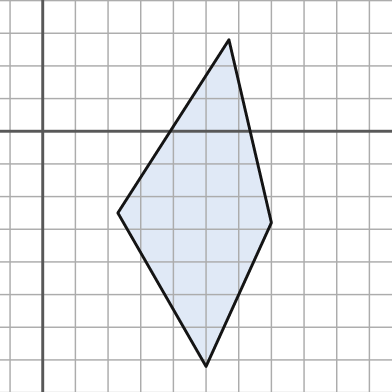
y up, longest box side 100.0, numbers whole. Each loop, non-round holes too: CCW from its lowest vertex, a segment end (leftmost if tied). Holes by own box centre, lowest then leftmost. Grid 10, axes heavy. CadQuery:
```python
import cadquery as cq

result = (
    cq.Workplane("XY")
    .moveTo(50.0, -72.0)
    .lineTo(70.0, -28.0)
    .lineTo(57.0, 28.0)
    .lineTo(23.0, -25.0)
    .close()
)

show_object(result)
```